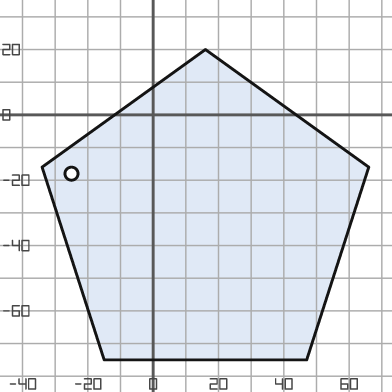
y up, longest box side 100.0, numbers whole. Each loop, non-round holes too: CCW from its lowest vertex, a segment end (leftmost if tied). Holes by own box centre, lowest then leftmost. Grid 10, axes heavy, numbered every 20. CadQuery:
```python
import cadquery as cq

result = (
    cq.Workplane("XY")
    .moveTo(-15.0, -75.0)
    .lineTo(47.0, -75.0)
    .lineTo(66.0, -16.0)
    .lineTo(16.0, 20.0)
    .lineTo(-34.0, -16.0)
    .close()
    .moveTo(-25.0, -18.0)
    .circle(2.0)
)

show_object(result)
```